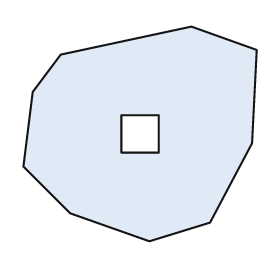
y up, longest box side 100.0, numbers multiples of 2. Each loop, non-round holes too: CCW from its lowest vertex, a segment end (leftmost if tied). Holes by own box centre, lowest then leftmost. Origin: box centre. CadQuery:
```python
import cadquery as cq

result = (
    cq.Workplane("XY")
    .moveTo(4.0, -46.0)
    .lineTo(30.0, -38.0)
    .lineTo(48.0, -4.0)
    .lineTo(50.0, 36.0)
    .lineTo(22.0, 46.0)
    .lineTo(-34.0, 34.0)
    .lineTo(-46.0, 18.0)
    .lineTo(-50.0, -14.0)
    .lineTo(-30.0, -34.0)
    .close()
    .moveTo(-8.0, -8.0)
    .lineTo(8.0, -8.0)
    .lineTo(8.0, 8.0)
    .lineTo(-8.0, 8.0)
    .close()
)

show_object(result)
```